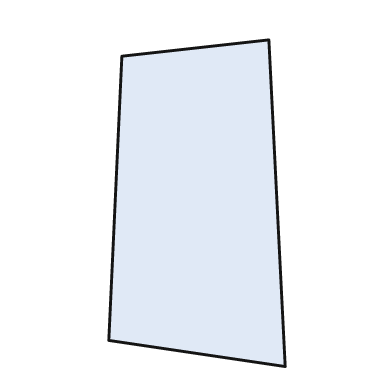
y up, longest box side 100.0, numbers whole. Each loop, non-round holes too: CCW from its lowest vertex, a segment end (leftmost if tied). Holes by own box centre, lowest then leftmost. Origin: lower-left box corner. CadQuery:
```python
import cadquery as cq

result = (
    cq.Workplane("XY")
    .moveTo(54.0, 0.0)
    .lineTo(49.0, 100.0)
    .lineTo(4.0, 95.0)
    .lineTo(0.0, 8.0)
    .close()
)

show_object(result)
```